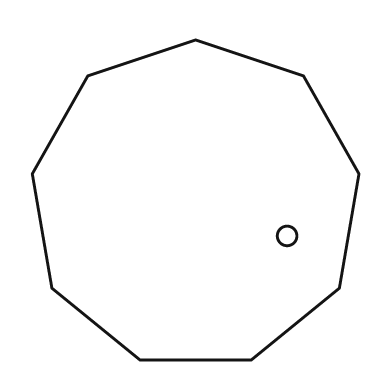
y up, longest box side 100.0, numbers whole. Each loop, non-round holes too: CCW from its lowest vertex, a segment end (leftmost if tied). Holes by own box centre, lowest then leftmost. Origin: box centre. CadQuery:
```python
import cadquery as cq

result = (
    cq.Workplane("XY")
    .moveTo(-17.0, -49.0)
    .lineTo(17.0, -49.0)
    .lineTo(44.0, -27.0)
    .lineTo(50.0, 8.0)
    .lineTo(33.0, 38.0)
    .lineTo(0.0, 49.0)
    .lineTo(-33.0, 38.0)
    .lineTo(-50.0, 8.0)
    .lineTo(-44.0, -27.0)
    .close()
    .moveTo(28.0, -11.0)
    .circle(3.0)
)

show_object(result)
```